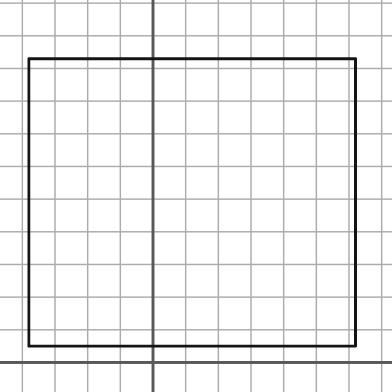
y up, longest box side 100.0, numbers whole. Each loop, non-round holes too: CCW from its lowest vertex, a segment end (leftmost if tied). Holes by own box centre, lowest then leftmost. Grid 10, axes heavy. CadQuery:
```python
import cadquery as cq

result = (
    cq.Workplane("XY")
    .moveTo(-38.0, 5.0)
    .lineTo(62.0, 5.0)
    .lineTo(62.0, 93.0)
    .lineTo(-38.0, 93.0)
    .close()
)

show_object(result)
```